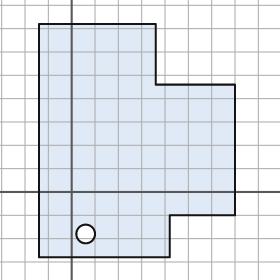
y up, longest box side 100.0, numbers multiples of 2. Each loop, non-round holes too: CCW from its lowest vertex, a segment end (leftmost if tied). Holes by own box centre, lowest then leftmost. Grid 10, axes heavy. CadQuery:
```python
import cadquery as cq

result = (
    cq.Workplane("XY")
    .moveTo(-14.0, -28.0)
    .lineTo(42.0, -28.0)
    .lineTo(42.0, -10.0)
    .lineTo(70.0, -10.0)
    .lineTo(70.0, 46.0)
    .lineTo(36.0, 46.0)
    .lineTo(36.0, 72.0)
    .lineTo(-14.0, 72.0)
    .close()
    .moveTo(6.0, -18.0)
    .circle(4.0)
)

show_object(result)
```